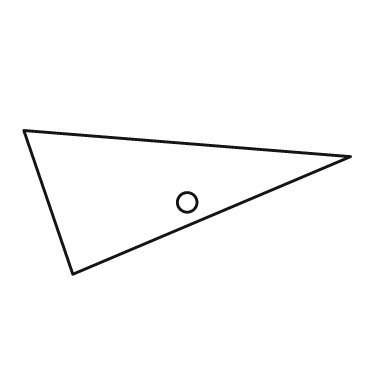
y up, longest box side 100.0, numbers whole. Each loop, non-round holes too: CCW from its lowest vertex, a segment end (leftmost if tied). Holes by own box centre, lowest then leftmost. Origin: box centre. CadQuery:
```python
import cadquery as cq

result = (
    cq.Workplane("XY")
    .moveTo(-35.0, -22.0)
    .lineTo(50.0, 14.0)
    .lineTo(-50.0, 22.0)
    .close()
    .moveTo(0.0, 0.0)
    .circle(3.0)
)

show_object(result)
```